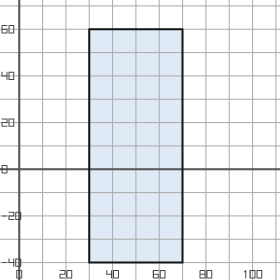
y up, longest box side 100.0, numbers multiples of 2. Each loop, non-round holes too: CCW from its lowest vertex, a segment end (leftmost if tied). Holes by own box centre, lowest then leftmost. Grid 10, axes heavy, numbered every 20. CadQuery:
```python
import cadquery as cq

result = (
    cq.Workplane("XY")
    .moveTo(30.0, -40.0)
    .lineTo(70.0, -40.0)
    .lineTo(70.0, 60.0)
    .lineTo(30.0, 60.0)
    .close()
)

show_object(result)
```